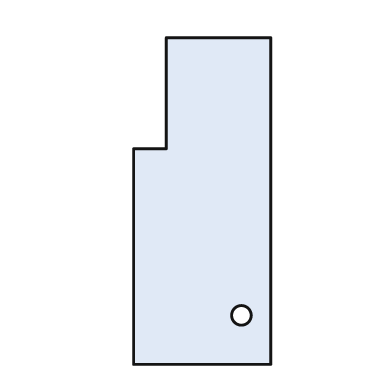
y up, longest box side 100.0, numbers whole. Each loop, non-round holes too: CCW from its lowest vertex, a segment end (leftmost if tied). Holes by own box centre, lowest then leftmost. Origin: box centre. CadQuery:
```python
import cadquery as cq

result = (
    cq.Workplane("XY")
    .moveTo(-21.0, -50.0)
    .lineTo(21.0, -50.0)
    .lineTo(21.0, 50.0)
    .lineTo(-11.0, 50.0)
    .lineTo(-11.0, 16.0)
    .lineTo(-21.0, 16.0)
    .close()
    .moveTo(12.0, -35.0)
    .circle(3.0)
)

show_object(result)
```